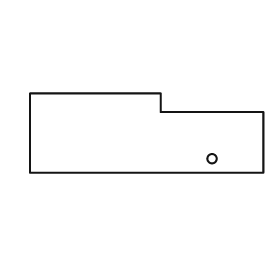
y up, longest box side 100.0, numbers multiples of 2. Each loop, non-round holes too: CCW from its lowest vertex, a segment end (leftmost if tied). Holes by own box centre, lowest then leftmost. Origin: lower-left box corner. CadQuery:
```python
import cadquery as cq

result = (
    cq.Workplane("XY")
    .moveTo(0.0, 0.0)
    .lineTo(100.0, 0.0)
    .lineTo(100.0, 26.0)
    .lineTo(56.0, 26.0)
    .lineTo(56.0, 34.0)
    .lineTo(0.0, 34.0)
    .close()
    .moveTo(78.0, 6.0)
    .circle(2.0)
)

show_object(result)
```